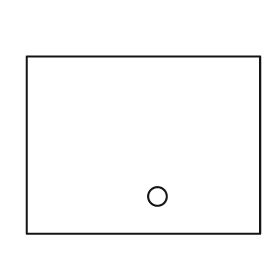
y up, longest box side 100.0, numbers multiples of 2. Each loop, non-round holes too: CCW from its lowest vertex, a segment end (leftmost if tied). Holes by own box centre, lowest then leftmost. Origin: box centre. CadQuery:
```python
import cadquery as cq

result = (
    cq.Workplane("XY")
    .moveTo(-50.0, -38.0)
    .lineTo(50.0, -38.0)
    .lineTo(50.0, 38.0)
    .lineTo(-50.0, 38.0)
    .close()
    .moveTo(6.0, -22.0)
    .circle(4.0)
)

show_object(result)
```